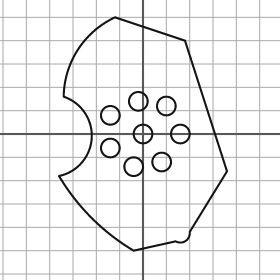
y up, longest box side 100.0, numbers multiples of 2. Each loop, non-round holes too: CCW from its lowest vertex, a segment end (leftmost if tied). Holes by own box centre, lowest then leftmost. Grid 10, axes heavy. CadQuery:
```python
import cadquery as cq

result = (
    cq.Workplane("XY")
    .moveTo(-4.0, -50.0)
    .lineTo(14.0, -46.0)
    .threePointArc((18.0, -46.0), (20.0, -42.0))
    .lineTo(36.0, -16.0)
    .lineTo(18.0, 40.0)
    .lineTo(-12.0, 50.0)
    .threePointArc((-28.0, 36.0), (-34.0, 16.0))
    .threePointArc((-22.0, -2.0), (-36.0, -18.0))
    .threePointArc((-22.0, -36.0), (-4.0, -50.0))
    .close()
    .moveTo(-4.0, -14.0)
    .circle(4.0)
    .moveTo(8.0, -12.0)
    .circle(4.0)
    .moveTo(-14.0, -6.0)
    .circle(4.0)
    .moveTo(0.0, 0.0)
    .circle(4.0)
    .moveTo(16.0, 0.0)
    .circle(4.0)
    .moveTo(-14.0, 8.0)
    .circle(4.0)
    .moveTo(10.0, 12.0)
    .circle(4.0)
    .moveTo(-2.0, 14.0)
    .circle(4.0)
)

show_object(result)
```